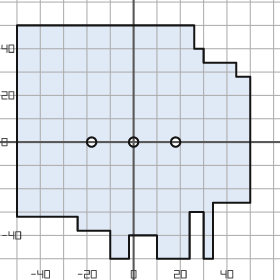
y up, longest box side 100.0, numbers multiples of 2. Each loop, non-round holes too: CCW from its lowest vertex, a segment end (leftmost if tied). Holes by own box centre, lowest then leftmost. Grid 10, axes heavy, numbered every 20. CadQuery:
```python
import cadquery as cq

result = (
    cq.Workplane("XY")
    .moveTo(-10.0, -50.0)
    .lineTo(-2.0, -50.0)
    .lineTo(-2.0, -40.0)
    .lineTo(10.0, -40.0)
    .lineTo(10.0, -50.0)
    .lineTo(24.0, -50.0)
    .lineTo(24.0, -30.0)
    .lineTo(30.0, -30.0)
    .lineTo(30.0, -50.0)
    .lineTo(34.0, -50.0)
    .lineTo(34.0, -26.0)
    .lineTo(50.0, -26.0)
    .lineTo(50.0, 28.0)
    .lineTo(44.0, 28.0)
    .lineTo(44.0, 34.0)
    .lineTo(30.0, 34.0)
    .lineTo(30.0, 40.0)
    .lineTo(26.0, 40.0)
    .lineTo(26.0, 50.0)
    .lineTo(-50.0, 50.0)
    .lineTo(-50.0, -32.0)
    .lineTo(-24.0, -32.0)
    .lineTo(-24.0, -38.0)
    .lineTo(-10.0, -38.0)
    .close()
    .moveTo(-18.0, 0.0)
    .circle(2.0)
    .moveTo(0.0, 0.0)
    .circle(2.0)
    .moveTo(18.0, 0.0)
    .circle(2.0)
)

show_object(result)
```